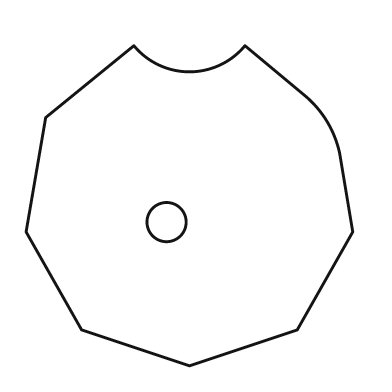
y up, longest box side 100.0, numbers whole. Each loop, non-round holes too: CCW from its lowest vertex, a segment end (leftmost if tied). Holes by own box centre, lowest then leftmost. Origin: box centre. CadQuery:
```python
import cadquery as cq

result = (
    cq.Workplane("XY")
    .moveTo(0.0, -49.0)
    .lineTo(33.0, -38.0)
    .lineTo(50.0, -8.0)
    .lineTo(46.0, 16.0)
    .threePointArc((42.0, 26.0), (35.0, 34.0))
    .lineTo(17.0, 49.0)
    .threePointArc((0.0, 41.0), (-17.0, 49.0))
    .lineTo(-44.0, 27.0)
    .lineTo(-50.0, -8.0)
    .lineTo(-33.0, -38.0)
    .close()
    .moveTo(-7.0, -5.0)
    .circle(6.0)
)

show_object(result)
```